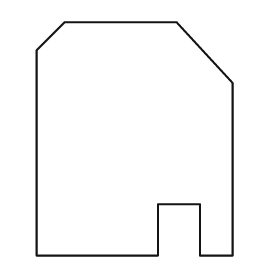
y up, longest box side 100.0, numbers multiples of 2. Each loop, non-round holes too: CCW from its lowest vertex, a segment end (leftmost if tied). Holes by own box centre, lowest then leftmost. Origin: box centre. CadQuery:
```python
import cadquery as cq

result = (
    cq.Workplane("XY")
    .moveTo(-42.0, -50.0)
    .lineTo(10.0, -50.0)
    .lineTo(10.0, -28.0)
    .lineTo(28.0, -28.0)
    .lineTo(28.0, -50.0)
    .lineTo(42.0, -50.0)
    .lineTo(42.0, 24.0)
    .lineTo(18.0, 50.0)
    .lineTo(-30.0, 50.0)
    .lineTo(-42.0, 38.0)
    .close()
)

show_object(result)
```